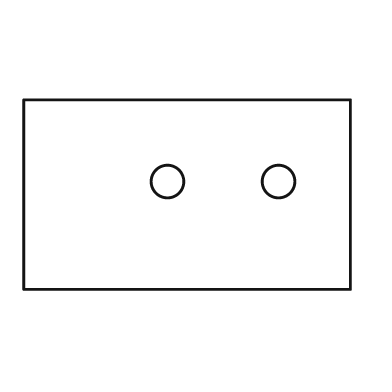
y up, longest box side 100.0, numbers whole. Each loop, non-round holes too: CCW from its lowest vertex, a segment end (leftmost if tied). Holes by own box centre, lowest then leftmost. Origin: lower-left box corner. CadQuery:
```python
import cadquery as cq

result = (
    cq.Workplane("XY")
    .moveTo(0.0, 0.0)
    .lineTo(100.0, 0.0)
    .lineTo(100.0, 58.0)
    .lineTo(0.0, 58.0)
    .close()
    .moveTo(44.0, 33.0)
    .circle(5.0)
    .moveTo(78.0, 33.0)
    .circle(5.0)
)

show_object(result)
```